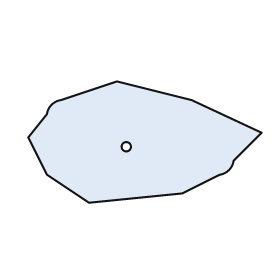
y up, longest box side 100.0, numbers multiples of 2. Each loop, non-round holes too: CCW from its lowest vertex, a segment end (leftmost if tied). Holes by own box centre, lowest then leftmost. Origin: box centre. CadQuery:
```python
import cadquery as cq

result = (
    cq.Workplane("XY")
    .moveTo(-24.0, -26.0)
    .lineTo(16.0, -22.0)
    .lineTo(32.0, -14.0)
    .threePointArc((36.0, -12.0), (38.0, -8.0))
    .lineTo(50.0, 4.0)
    .lineTo(20.0, 18.0)
    .lineTo(-12.0, 26.0)
    .lineTo(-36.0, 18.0)
    .threePointArc((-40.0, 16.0), (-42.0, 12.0))
    .lineTo(-50.0, 2.0)
    .lineTo(-42.0, -14.0)
    .close()
    .moveTo(-8.0, -2.0)
    .circle(2.0)
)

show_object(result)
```